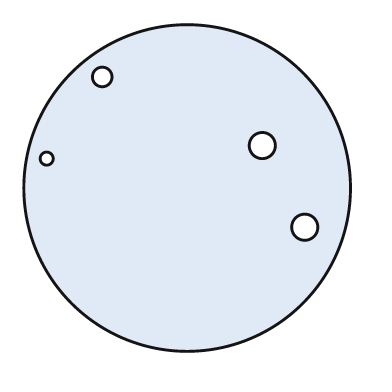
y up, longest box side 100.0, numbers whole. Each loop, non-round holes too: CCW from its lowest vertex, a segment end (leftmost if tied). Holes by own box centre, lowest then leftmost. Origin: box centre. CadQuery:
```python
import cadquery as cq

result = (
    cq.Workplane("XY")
    .moveTo(0.0, 0.0)
    .circle(50.0)
    .moveTo(36.0, -12.0)
    .circle(4.0)
    .moveTo(-43.0, 9.0)
    .circle(2.0)
    .moveTo(23.0, 13.0)
    .circle(4.0)
    .moveTo(-26.0, 34.0)
    .circle(3.0)
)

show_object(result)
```